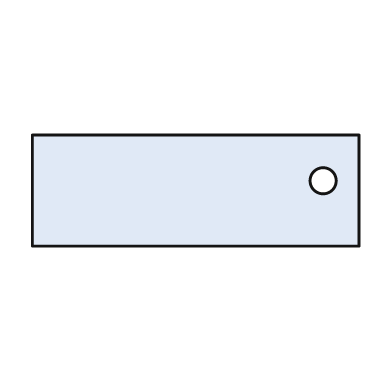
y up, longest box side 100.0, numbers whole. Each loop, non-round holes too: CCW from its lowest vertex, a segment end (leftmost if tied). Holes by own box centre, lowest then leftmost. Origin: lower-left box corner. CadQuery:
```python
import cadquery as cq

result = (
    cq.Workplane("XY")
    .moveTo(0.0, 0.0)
    .lineTo(100.0, 0.0)
    .lineTo(100.0, 34.0)
    .lineTo(0.0, 34.0)
    .close()
    .moveTo(89.0, 20.0)
    .circle(4.0)
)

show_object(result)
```